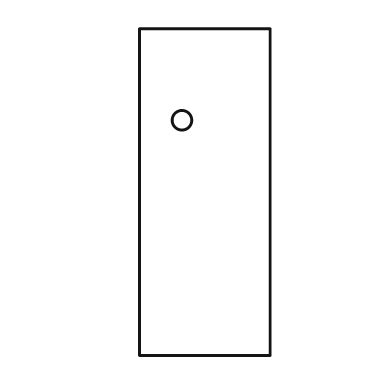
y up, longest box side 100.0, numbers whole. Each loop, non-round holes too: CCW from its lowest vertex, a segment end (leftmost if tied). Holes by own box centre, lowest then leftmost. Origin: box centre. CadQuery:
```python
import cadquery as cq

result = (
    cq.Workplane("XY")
    .moveTo(-20.0, -50.0)
    .lineTo(20.0, -50.0)
    .lineTo(20.0, 50.0)
    .lineTo(-20.0, 50.0)
    .close()
    .moveTo(-7.0, 22.0)
    .circle(3.0)
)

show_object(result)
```